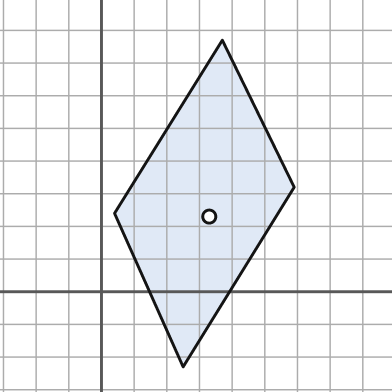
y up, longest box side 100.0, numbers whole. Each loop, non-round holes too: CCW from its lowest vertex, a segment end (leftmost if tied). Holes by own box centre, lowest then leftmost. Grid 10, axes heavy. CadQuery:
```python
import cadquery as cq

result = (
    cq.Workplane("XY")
    .moveTo(25.0, -23.0)
    .lineTo(59.0, 32.0)
    .lineTo(37.0, 77.0)
    .lineTo(4.0, 24.0)
    .close()
    .moveTo(33.0, 23.0)
    .circle(2.0)
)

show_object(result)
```